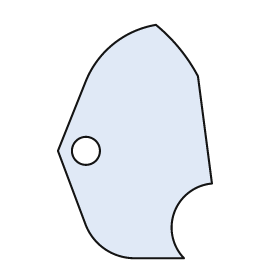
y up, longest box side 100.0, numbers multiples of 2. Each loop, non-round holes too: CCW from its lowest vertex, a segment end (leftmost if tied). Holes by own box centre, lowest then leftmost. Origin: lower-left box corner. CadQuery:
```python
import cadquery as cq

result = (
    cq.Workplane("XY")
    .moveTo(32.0, 0.0)
    .lineTo(54.0, 0.0)
    .threePointArc((50.0, 20.0), (66.0, 32.0))
    .lineTo(60.0, 78.0)
    .threePointArc((52.0, 90.0), (42.0, 100.0))
    .threePointArc((24.0, 92.0), (12.0, 76.0))
    .lineTo(0.0, 46.0)
    .lineTo(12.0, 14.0)
    .threePointArc((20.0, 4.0), (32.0, 0.0))
    .close()
    .moveTo(12.0, 46.0)
    .circle(6.0)
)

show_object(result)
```